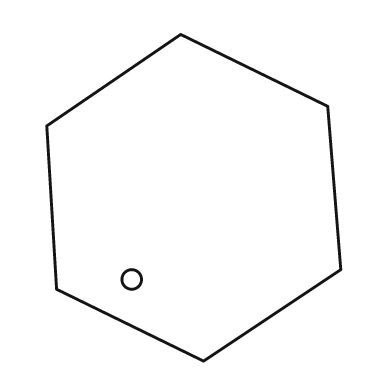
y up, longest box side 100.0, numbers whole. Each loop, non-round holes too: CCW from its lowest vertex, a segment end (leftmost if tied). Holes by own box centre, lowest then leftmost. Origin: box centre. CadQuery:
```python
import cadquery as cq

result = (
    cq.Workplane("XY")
    .moveTo(3.0, -50.0)
    .lineTo(45.0, -22.0)
    .lineTo(41.0, 28.0)
    .lineTo(-4.0, 50.0)
    .lineTo(-45.0, 22.0)
    .lineTo(-42.0, -28.0)
    .close()
    .moveTo(-19.0, -25.0)
    .circle(3.0)
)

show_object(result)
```